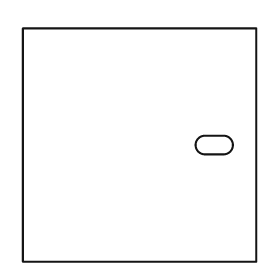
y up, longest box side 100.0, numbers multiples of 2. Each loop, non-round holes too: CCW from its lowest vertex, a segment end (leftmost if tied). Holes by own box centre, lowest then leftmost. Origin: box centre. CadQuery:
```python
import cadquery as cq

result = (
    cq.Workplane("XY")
    .moveTo(-50.0, -50.0)
    .lineTo(50.0, -50.0)
    .lineTo(50.0, 50.0)
    .lineTo(-50.0, 50.0)
    .close()
    .moveTo(28.0, -4.0)
    .lineTo(36.0, -4.0)
    .threePointArc((40.0, 0.0), (36.0, 4.0))
    .lineTo(28.0, 4.0)
    .threePointArc((24.0, 0.0), (28.0, -4.0))
    .close()
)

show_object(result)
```